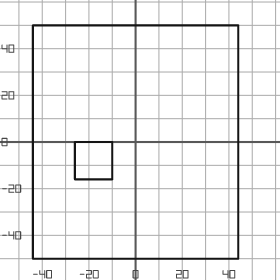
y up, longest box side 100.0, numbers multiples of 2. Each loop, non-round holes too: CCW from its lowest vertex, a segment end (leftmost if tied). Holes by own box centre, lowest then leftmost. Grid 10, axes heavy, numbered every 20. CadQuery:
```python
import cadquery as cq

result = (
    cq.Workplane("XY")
    .moveTo(-44.0, -50.0)
    .lineTo(44.0, -50.0)
    .lineTo(44.0, 50.0)
    .lineTo(-44.0, 50.0)
    .close()
    .moveTo(-26.0, -16.0)
    .lineTo(-10.0, -16.0)
    .lineTo(-10.0, 0.0)
    .lineTo(-26.0, 0.0)
    .close()
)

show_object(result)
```